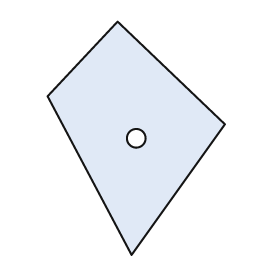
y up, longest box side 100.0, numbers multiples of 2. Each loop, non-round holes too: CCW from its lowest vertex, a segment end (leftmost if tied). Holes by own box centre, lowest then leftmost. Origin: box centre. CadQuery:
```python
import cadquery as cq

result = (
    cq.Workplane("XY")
    .moveTo(-2.0, -50.0)
    .lineTo(38.0, 6.0)
    .lineTo(-8.0, 50.0)
    .lineTo(-38.0, 18.0)
    .close()
    .moveTo(0.0, 0.0)
    .circle(4.0)
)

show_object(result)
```